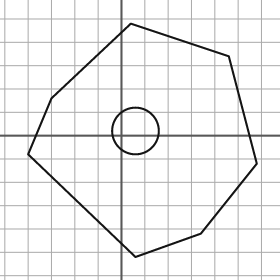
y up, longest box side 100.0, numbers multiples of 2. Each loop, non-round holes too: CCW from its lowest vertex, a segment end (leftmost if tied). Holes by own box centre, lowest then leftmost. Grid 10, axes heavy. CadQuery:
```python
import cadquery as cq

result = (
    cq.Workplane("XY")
    .moveTo(6.0, -52.0)
    .lineTo(34.0, -42.0)
    .lineTo(58.0, -12.0)
    .lineTo(46.0, 34.0)
    .lineTo(4.0, 48.0)
    .lineTo(-30.0, 16.0)
    .lineTo(-40.0, -8.0)
    .close()
    .moveTo(6.0, 2.0)
    .circle(10.0)
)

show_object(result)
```